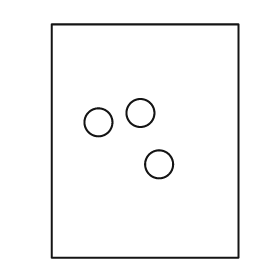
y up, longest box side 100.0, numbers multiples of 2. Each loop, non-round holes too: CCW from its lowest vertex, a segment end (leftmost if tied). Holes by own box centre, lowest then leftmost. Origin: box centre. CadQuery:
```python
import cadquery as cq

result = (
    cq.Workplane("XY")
    .moveTo(-40.0, -50.0)
    .lineTo(40.0, -50.0)
    .lineTo(40.0, 50.0)
    .lineTo(-40.0, 50.0)
    .close()
    .moveTo(6.0, -10.0)
    .circle(6.0)
    .moveTo(-20.0, 8.0)
    .circle(6.0)
    .moveTo(-2.0, 12.0)
    .circle(6.0)
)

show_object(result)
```